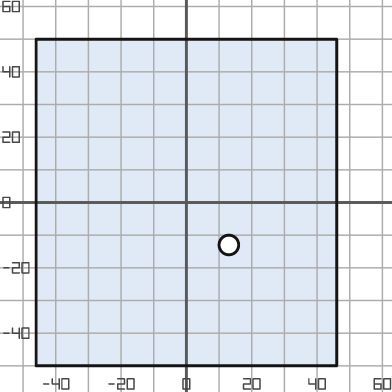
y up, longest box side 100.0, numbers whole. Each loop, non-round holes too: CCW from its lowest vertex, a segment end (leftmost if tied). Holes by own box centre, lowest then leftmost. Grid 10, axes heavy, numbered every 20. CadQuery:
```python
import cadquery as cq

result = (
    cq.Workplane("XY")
    .moveTo(-46.0, -50.0)
    .lineTo(46.0, -50.0)
    .lineTo(46.0, 50.0)
    .lineTo(-46.0, 50.0)
    .close()
    .moveTo(13.0, -13.0)
    .circle(3.0)
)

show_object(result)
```